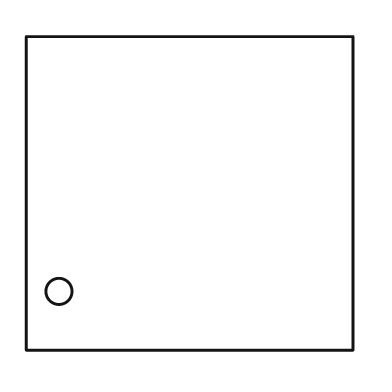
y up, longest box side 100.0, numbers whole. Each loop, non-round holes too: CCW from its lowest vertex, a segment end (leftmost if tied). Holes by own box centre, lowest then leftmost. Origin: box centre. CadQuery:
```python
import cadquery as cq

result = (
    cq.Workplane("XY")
    .moveTo(-50.0, -48.0)
    .lineTo(50.0, -48.0)
    .lineTo(50.0, 48.0)
    .lineTo(-50.0, 48.0)
    .close()
    .moveTo(-40.0, -30.0)
    .circle(4.0)
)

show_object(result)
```